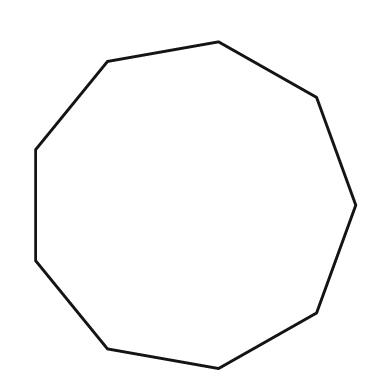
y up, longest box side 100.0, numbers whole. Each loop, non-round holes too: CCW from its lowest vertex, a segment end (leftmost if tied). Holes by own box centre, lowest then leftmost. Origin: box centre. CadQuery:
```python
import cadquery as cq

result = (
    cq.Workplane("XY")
    .moveTo(7.0, -50.0)
    .lineTo(37.0, -33.0)
    .lineTo(49.0, 0.0)
    .lineTo(37.0, 33.0)
    .lineTo(7.0, 50.0)
    .lineTo(-27.0, 44.0)
    .lineTo(-49.0, 17.0)
    .lineTo(-49.0, -17.0)
    .lineTo(-27.0, -44.0)
    .close()
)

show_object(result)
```